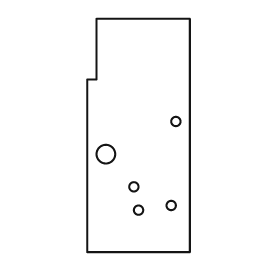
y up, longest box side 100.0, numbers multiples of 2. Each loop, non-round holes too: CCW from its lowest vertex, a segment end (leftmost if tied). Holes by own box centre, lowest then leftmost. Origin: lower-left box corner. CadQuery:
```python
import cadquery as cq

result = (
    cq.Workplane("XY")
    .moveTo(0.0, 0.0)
    .lineTo(44.0, 0.0)
    .lineTo(44.0, 100.0)
    .lineTo(4.0, 100.0)
    .lineTo(4.0, 74.0)
    .lineTo(0.0, 74.0)
    .close()
    .moveTo(22.0, 18.0)
    .circle(2.0)
    .moveTo(36.0, 20.0)
    .circle(2.0)
    .moveTo(20.0, 28.0)
    .circle(2.0)
    .moveTo(8.0, 42.0)
    .circle(4.0)
    .moveTo(38.0, 56.0)
    .circle(2.0)
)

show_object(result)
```